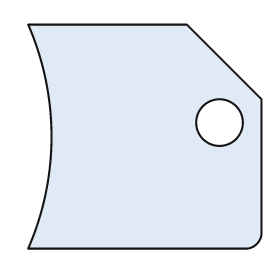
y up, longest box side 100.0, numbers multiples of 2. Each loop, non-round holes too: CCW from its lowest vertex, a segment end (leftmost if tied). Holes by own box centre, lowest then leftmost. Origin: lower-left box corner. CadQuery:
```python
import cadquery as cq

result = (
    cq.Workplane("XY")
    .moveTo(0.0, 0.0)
    .lineTo(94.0, 0.0)
    .threePointArc((98.0, 2.0), (100.0, 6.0))
    .lineTo(100.0, 64.0)
    .lineTo(68.0, 96.0)
    .lineTo(0.0, 96.0)
    .threePointArc((10.0, 48.0), (0.0, 0.0))
    .close()
    .moveTo(82.0, 54.0)
    .circle(10.0)
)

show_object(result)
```